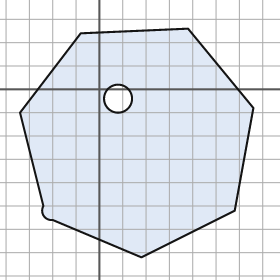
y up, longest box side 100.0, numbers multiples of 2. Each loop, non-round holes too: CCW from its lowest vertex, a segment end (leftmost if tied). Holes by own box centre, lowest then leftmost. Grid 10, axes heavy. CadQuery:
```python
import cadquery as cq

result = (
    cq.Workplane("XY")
    .moveTo(18.0, -72.0)
    .lineTo(58.0, -52.0)
    .lineTo(66.0, -8.0)
    .lineTo(38.0, 26.0)
    .lineTo(-8.0, 24.0)
    .lineTo(-34.0, -10.0)
    .lineTo(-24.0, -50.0)
    .threePointArc((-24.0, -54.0), (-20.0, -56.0))
    .close()
    .moveTo(8.0, -4.0)
    .circle(6.0)
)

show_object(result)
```